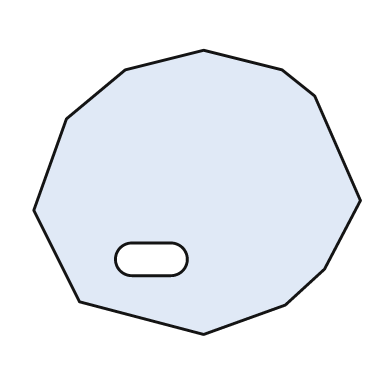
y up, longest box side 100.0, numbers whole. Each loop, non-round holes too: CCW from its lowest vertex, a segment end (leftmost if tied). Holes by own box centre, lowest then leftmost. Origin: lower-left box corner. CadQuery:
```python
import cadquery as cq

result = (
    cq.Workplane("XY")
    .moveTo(52.0, 0.0)
    .lineTo(77.0, 9.0)
    .lineTo(89.0, 20.0)
    .lineTo(100.0, 41.0)
    .lineTo(86.0, 73.0)
    .lineTo(76.0, 81.0)
    .lineTo(52.0, 87.0)
    .lineTo(28.0, 81.0)
    .lineTo(10.0, 66.0)
    .lineTo(0.0, 38.0)
    .lineTo(14.0, 10.0)
    .close()
    .moveTo(30.0, 18.0)
    .lineTo(42.0, 18.0)
    .threePointArc((47.0, 23.0), (42.0, 28.0))
    .lineTo(30.0, 28.0)
    .threePointArc((25.0, 23.0), (30.0, 18.0))
    .close()
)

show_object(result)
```